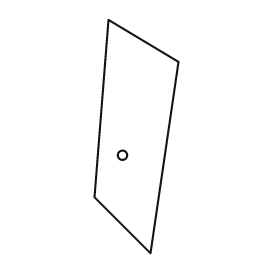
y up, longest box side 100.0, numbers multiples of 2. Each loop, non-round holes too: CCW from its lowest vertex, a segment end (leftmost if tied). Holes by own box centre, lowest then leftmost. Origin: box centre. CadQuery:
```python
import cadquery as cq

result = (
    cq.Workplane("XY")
    .moveTo(6.0, -50.0)
    .lineTo(18.0, 32.0)
    .lineTo(-12.0, 50.0)
    .lineTo(-18.0, -26.0)
    .close()
    .moveTo(-6.0, -8.0)
    .circle(2.0)
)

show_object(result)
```